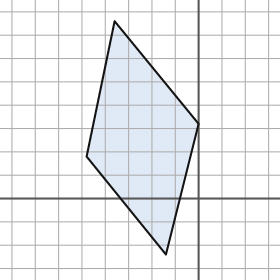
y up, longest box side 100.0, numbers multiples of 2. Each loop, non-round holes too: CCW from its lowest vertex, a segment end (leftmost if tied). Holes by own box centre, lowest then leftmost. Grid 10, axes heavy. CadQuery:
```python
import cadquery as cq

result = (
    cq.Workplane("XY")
    .moveTo(-14.0, -24.0)
    .lineTo(0.0, 32.0)
    .lineTo(-36.0, 76.0)
    .lineTo(-48.0, 18.0)
    .close()
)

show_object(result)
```